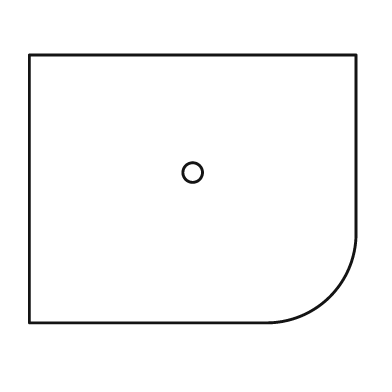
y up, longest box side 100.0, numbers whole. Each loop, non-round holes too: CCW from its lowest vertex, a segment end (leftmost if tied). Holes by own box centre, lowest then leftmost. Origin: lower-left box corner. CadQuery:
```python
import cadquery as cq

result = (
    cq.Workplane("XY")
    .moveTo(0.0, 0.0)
    .lineTo(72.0, 0.0)
    .threePointArc((92.0, 8.0), (100.0, 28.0))
    .lineTo(100.0, 82.0)
    .lineTo(0.0, 82.0)
    .close()
    .moveTo(50.0, 46.0)
    .circle(3.0)
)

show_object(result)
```